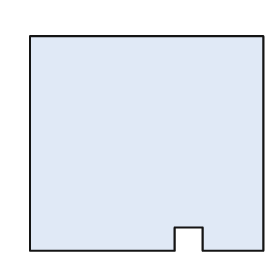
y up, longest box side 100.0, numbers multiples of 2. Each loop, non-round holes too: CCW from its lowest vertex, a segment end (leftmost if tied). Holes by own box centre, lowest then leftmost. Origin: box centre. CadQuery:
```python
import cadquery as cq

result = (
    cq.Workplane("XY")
    .moveTo(-50.0, -46.0)
    .lineTo(12.0, -46.0)
    .lineTo(12.0, -36.0)
    .lineTo(24.0, -36.0)
    .lineTo(24.0, -46.0)
    .lineTo(50.0, -46.0)
    .lineTo(50.0, 46.0)
    .lineTo(-50.0, 46.0)
    .close()
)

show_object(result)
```